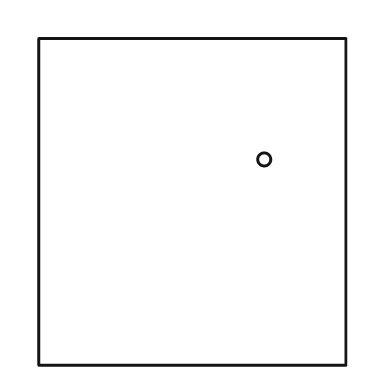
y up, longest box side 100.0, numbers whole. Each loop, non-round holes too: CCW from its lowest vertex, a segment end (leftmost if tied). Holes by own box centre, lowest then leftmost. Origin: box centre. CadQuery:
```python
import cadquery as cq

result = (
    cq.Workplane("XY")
    .moveTo(-47.0, -50.0)
    .lineTo(47.0, -50.0)
    .lineTo(47.0, 50.0)
    .lineTo(-47.0, 50.0)
    .close()
    .moveTo(22.0, 13.0)
    .circle(2.0)
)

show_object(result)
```